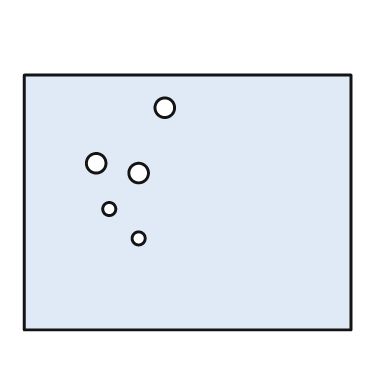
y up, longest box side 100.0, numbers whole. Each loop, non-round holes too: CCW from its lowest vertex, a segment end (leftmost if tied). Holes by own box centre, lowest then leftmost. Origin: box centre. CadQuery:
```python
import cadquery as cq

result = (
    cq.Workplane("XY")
    .moveTo(-50.0, -39.0)
    .lineTo(50.0, -39.0)
    .lineTo(50.0, 39.0)
    .lineTo(-50.0, 39.0)
    .close()
    .moveTo(-15.0, -11.0)
    .circle(2.0)
    .moveTo(-24.0, -2.0)
    .circle(2.0)
    .moveTo(-15.0, 9.0)
    .circle(3.0)
    .moveTo(-28.0, 12.0)
    .circle(3.0)
    .moveTo(-7.0, 29.0)
    .circle(3.0)
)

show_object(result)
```